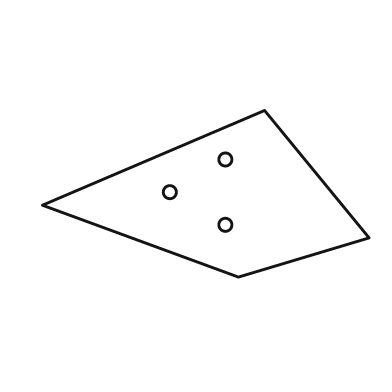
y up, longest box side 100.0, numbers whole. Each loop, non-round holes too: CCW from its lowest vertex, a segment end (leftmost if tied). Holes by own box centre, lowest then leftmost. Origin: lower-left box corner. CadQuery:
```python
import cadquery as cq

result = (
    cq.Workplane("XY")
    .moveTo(60.0, 0.0)
    .lineTo(100.0, 12.0)
    .lineTo(68.0, 51.0)
    .lineTo(0.0, 22.0)
    .close()
    .moveTo(56.0, 16.0)
    .circle(2.0)
    .moveTo(39.0, 26.0)
    .circle(2.0)
    .moveTo(56.0, 36.0)
    .circle(2.0)
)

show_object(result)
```